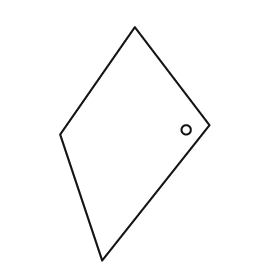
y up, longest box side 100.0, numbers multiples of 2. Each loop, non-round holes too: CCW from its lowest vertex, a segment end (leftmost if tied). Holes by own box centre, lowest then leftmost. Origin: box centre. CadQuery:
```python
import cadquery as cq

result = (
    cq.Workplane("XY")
    .moveTo(-14.0, -50.0)
    .lineTo(32.0, 8.0)
    .lineTo(0.0, 50.0)
    .lineTo(-32.0, 4.0)
    .close()
    .moveTo(22.0, 6.0)
    .circle(2.0)
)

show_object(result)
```